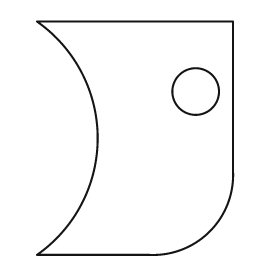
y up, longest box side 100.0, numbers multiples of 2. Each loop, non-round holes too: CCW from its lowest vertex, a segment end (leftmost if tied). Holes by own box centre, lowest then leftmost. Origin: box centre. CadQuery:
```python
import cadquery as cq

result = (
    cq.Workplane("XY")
    .moveTo(-42.0, -50.0)
    .lineTo(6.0, -50.0)
    .threePointArc((32.0, -40.0), (42.0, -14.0))
    .lineTo(42.0, 50.0)
    .lineTo(-42.0, 50.0)
    .threePointArc((-16.0, 0.0), (-42.0, -50.0))
    .close()
    .moveTo(26.0, 20.0)
    .circle(10.0)
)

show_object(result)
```